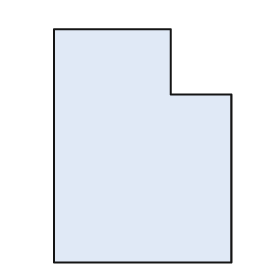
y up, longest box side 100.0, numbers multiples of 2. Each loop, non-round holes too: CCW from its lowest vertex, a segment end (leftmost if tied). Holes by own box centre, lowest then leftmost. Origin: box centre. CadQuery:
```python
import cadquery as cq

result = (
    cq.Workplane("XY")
    .moveTo(-38.0, -50.0)
    .lineTo(38.0, -50.0)
    .lineTo(38.0, 22.0)
    .lineTo(12.0, 22.0)
    .lineTo(12.0, 50.0)
    .lineTo(-38.0, 50.0)
    .close()
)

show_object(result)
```